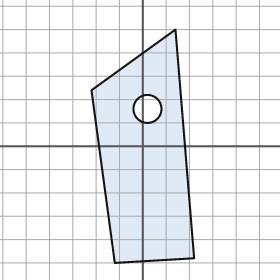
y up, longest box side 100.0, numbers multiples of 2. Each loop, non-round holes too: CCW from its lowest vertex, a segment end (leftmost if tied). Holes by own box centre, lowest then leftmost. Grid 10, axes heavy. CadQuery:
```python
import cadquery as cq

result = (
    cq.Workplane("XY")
    .moveTo(-12.0, -50.0)
    .lineTo(22.0, -48.0)
    .lineTo(14.0, 50.0)
    .lineTo(-22.0, 24.0)
    .close()
    .moveTo(2.0, 16.0)
    .circle(6.0)
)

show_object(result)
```